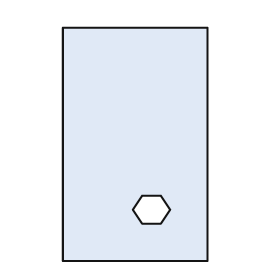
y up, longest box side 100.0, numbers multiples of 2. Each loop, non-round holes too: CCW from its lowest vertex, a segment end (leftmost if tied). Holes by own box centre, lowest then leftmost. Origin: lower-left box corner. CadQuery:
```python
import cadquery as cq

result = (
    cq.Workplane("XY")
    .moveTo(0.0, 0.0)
    .lineTo(62.0, 0.0)
    .lineTo(62.0, 100.0)
    .lineTo(0.0, 100.0)
    .close()
    .moveTo(34.0, 16.0)
    .lineTo(42.0, 16.0)
    .lineTo(46.0, 22.0)
    .lineTo(42.0, 28.0)
    .lineTo(34.0, 28.0)
    .lineTo(30.0, 22.0)
    .close()
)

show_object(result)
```